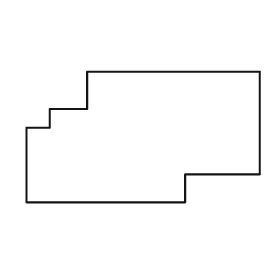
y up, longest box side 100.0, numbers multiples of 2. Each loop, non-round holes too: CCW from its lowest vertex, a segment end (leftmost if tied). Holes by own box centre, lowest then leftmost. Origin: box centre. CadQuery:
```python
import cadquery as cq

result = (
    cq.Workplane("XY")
    .moveTo(-50.0, -28.0)
    .lineTo(18.0, -28.0)
    .lineTo(18.0, -16.0)
    .lineTo(50.0, -16.0)
    .lineTo(50.0, 28.0)
    .lineTo(-24.0, 28.0)
    .lineTo(-24.0, 12.0)
    .lineTo(-40.0, 12.0)
    .lineTo(-40.0, 4.0)
    .lineTo(-50.0, 4.0)
    .close()
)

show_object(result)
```